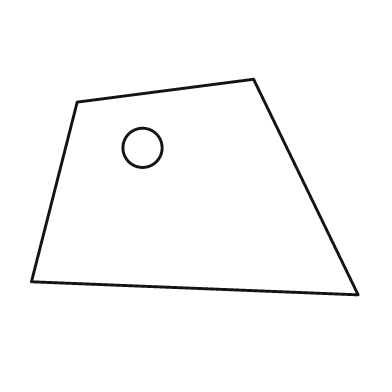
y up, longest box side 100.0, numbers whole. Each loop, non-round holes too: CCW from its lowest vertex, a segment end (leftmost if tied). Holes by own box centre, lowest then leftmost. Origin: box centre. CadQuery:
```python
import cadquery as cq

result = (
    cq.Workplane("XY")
    .moveTo(50.0, -33.0)
    .lineTo(18.0, 33.0)
    .lineTo(-36.0, 26.0)
    .lineTo(-50.0, -29.0)
    .close()
    .moveTo(-16.0, 12.0)
    .circle(6.0)
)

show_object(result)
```